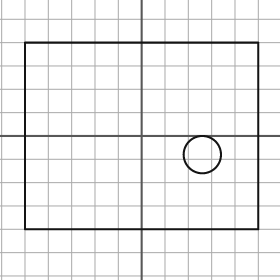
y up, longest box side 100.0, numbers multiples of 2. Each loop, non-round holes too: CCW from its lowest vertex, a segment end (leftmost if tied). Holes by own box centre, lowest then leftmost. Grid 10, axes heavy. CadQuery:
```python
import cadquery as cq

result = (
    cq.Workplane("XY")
    .moveTo(-50.0, -40.0)
    .lineTo(50.0, -40.0)
    .lineTo(50.0, 40.0)
    .lineTo(-50.0, 40.0)
    .close()
    .moveTo(26.0, -8.0)
    .circle(8.0)
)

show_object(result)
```